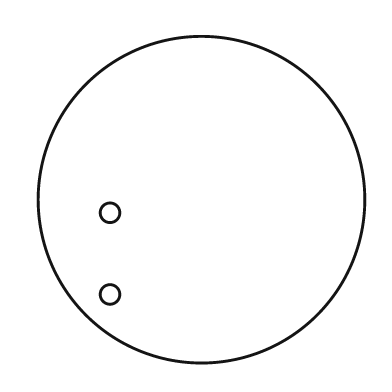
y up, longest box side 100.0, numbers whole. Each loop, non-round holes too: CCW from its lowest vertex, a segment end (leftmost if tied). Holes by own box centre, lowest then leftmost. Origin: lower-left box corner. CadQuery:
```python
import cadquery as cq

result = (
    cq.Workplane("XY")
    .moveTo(50.0, 50.0)
    .circle(50.0)
    .moveTo(22.0, 21.0)
    .circle(3.0)
    .moveTo(22.0, 46.0)
    .circle(3.0)
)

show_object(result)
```